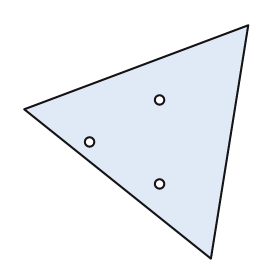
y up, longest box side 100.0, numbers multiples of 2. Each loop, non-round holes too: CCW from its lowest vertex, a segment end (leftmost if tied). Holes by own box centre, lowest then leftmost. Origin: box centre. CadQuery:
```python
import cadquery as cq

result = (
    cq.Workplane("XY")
    .moveTo(32.0, -50.0)
    .lineTo(48.0, 50.0)
    .lineTo(-48.0, 14.0)
    .close()
    .moveTo(10.0, -18.0)
    .circle(2.0)
    .moveTo(-20.0, 0.0)
    .circle(2.0)
    .moveTo(10.0, 18.0)
    .circle(2.0)
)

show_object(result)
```